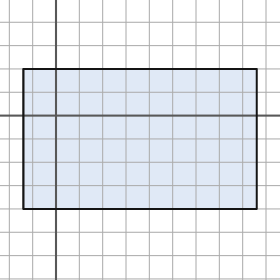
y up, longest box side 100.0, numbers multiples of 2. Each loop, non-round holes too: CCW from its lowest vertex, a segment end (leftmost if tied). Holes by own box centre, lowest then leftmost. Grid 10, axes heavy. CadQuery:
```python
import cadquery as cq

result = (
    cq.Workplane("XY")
    .moveTo(-14.0, -40.0)
    .lineTo(86.0, -40.0)
    .lineTo(86.0, 20.0)
    .lineTo(-14.0, 20.0)
    .close()
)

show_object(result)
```